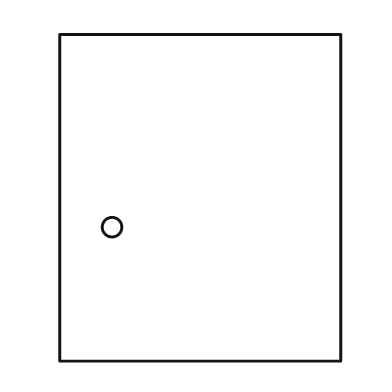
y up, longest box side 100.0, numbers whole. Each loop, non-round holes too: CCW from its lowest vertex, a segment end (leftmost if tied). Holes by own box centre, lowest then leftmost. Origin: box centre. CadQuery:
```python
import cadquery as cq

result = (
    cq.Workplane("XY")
    .moveTo(-43.0, -50.0)
    .lineTo(43.0, -50.0)
    .lineTo(43.0, 50.0)
    .lineTo(-43.0, 50.0)
    .close()
    .moveTo(-27.0, -9.0)
    .circle(3.0)
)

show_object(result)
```